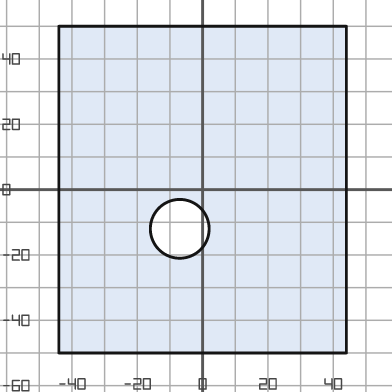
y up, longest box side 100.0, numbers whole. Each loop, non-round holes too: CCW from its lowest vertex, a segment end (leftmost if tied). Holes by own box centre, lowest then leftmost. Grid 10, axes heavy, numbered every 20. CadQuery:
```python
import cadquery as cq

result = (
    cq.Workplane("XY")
    .moveTo(-44.0, -50.0)
    .lineTo(44.0, -50.0)
    .lineTo(44.0, 50.0)
    .lineTo(-44.0, 50.0)
    .close()
    .moveTo(-7.0, -12.0)
    .circle(9.0)
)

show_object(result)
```